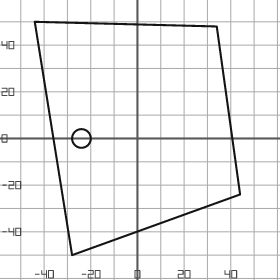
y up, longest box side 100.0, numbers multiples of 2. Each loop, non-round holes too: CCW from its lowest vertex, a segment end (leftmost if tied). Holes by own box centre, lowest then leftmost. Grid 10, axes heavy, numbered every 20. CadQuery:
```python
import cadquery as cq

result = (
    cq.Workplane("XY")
    .moveTo(-28.0, -50.0)
    .lineTo(44.0, -24.0)
    .lineTo(34.0, 48.0)
    .lineTo(-44.0, 50.0)
    .close()
    .moveTo(-24.0, 0.0)
    .circle(4.0)
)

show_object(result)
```